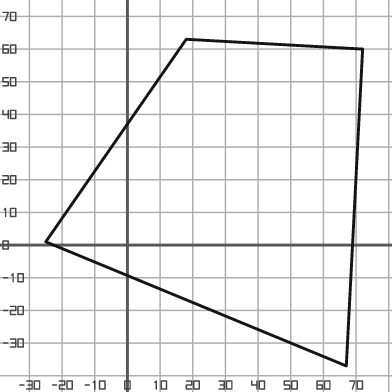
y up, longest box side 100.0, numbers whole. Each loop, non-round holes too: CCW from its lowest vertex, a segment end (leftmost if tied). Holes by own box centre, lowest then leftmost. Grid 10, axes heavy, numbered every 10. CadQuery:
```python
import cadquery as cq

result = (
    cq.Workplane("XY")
    .moveTo(67.0, -37.0)
    .lineTo(72.0, 60.0)
    .lineTo(18.0, 63.0)
    .lineTo(-25.0, 1.0)
    .close()
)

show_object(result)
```